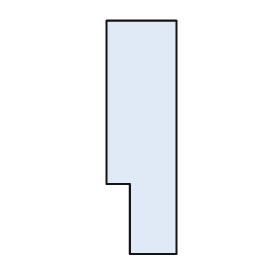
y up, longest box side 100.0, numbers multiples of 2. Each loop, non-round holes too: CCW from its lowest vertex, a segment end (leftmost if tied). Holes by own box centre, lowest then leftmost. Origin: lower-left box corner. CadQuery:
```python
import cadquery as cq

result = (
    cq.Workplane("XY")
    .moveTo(10.0, 0.0)
    .lineTo(30.0, 0.0)
    .lineTo(30.0, 100.0)
    .lineTo(0.0, 100.0)
    .lineTo(0.0, 30.0)
    .lineTo(10.0, 30.0)
    .close()
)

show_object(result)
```